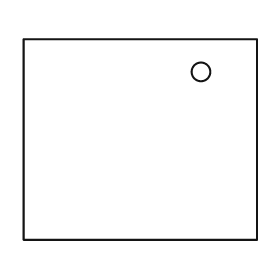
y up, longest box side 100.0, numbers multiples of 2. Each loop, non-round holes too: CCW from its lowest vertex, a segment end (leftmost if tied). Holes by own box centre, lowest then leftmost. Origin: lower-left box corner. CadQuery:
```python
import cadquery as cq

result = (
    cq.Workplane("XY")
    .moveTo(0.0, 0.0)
    .lineTo(100.0, 0.0)
    .lineTo(100.0, 86.0)
    .lineTo(0.0, 86.0)
    .close()
    .moveTo(76.0, 72.0)
    .circle(4.0)
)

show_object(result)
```